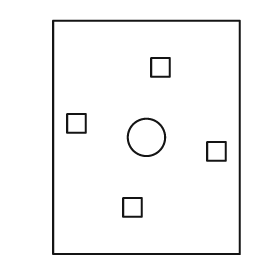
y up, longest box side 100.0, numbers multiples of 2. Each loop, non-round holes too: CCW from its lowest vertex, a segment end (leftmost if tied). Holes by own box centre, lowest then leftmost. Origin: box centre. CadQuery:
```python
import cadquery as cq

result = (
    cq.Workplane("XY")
    .moveTo(-40.0, -50.0)
    .lineTo(40.0, -50.0)
    .lineTo(40.0, 50.0)
    .lineTo(-40.0, 50.0)
    .close()
    .moveTo(-10.0, -34.0)
    .lineTo(-2.0, -34.0)
    .lineTo(-2.0, -26.0)
    .lineTo(-10.0, -26.0)
    .close()
    .moveTo(26.0, -10.0)
    .lineTo(34.0, -10.0)
    .lineTo(34.0, -2.0)
    .lineTo(26.0, -2.0)
    .close()
    .moveTo(0.0, 0.0)
    .circle(8.0)
    .moveTo(-34.0, 2.0)
    .lineTo(-26.0, 2.0)
    .lineTo(-26.0, 10.0)
    .lineTo(-34.0, 10.0)
    .close()
    .moveTo(2.0, 26.0)
    .lineTo(10.0, 26.0)
    .lineTo(10.0, 34.0)
    .lineTo(2.0, 34.0)
    .close()
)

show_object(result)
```